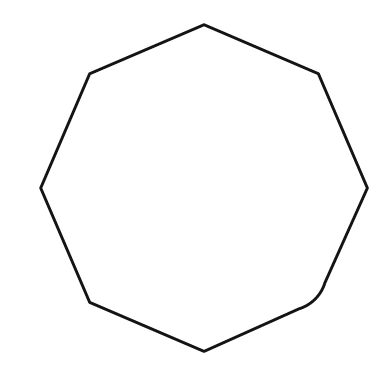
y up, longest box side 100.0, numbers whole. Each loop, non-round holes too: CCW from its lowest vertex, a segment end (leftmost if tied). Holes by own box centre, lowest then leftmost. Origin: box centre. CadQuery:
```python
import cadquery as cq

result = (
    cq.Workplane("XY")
    .moveTo(0.0, -50.0)
    .lineTo(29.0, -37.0)
    .threePointArc((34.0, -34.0), (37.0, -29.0))
    .lineTo(50.0, 0.0)
    .lineTo(35.0, 35.0)
    .lineTo(0.0, 50.0)
    .lineTo(-35.0, 35.0)
    .lineTo(-50.0, 0.0)
    .lineTo(-35.0, -35.0)
    .close()
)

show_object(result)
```